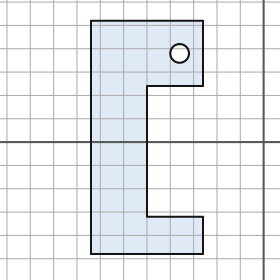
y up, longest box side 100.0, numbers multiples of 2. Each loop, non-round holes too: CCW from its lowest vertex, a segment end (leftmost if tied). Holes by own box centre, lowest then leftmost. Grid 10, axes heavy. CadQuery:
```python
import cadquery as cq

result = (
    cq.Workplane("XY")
    .moveTo(-74.0, -48.0)
    .lineTo(-26.0, -48.0)
    .lineTo(-26.0, -32.0)
    .lineTo(-50.0, -32.0)
    .lineTo(-50.0, 24.0)
    .lineTo(-26.0, 24.0)
    .lineTo(-26.0, 52.0)
    .lineTo(-74.0, 52.0)
    .close()
    .moveTo(-36.0, 38.0)
    .circle(4.0)
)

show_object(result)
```